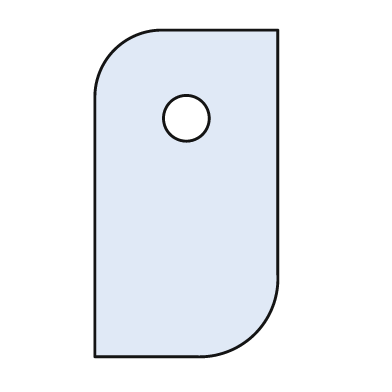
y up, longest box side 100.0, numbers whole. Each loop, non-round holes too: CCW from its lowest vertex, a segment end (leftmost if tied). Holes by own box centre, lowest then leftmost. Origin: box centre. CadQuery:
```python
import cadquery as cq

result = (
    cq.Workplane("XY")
    .moveTo(-28.0, -50.0)
    .lineTo(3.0, -50.0)
    .threePointArc((21.0, -43.0), (28.0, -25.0))
    .lineTo(28.0, 50.0)
    .lineTo(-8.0, 50.0)
    .threePointArc((-22.0, 44.0), (-28.0, 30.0))
    .close()
    .moveTo(0.0, 23.0)
    .circle(7.0)
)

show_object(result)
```